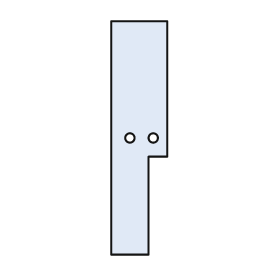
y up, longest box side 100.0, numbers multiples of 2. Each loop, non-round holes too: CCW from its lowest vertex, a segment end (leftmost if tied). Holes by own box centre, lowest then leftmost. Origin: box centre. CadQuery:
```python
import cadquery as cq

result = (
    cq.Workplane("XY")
    .moveTo(-12.0, -50.0)
    .lineTo(4.0, -50.0)
    .lineTo(4.0, -8.0)
    .lineTo(12.0, -8.0)
    .lineTo(12.0, 50.0)
    .lineTo(-12.0, 50.0)
    .close()
    .moveTo(-4.0, 0.0)
    .circle(2.0)
    .moveTo(6.0, 0.0)
    .circle(2.0)
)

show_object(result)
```